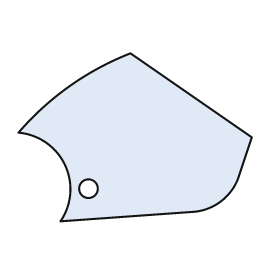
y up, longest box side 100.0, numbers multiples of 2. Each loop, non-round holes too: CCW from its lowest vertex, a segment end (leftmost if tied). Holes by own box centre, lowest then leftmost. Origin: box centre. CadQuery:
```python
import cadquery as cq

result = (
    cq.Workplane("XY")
    .moveTo(-32.0, -36.0)
    .lineTo(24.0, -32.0)
    .threePointArc((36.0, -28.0), (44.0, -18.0))
    .lineTo(50.0, 0.0)
    .lineTo(-2.0, 36.0)
    .threePointArc((-28.0, 22.0), (-50.0, 2.0))
    .threePointArc((-30.0, -12.0), (-32.0, -36.0))
    .close()
    .moveTo(-20.0, -22.0)
    .circle(4.0)
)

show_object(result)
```